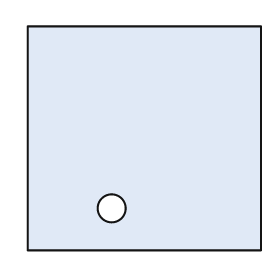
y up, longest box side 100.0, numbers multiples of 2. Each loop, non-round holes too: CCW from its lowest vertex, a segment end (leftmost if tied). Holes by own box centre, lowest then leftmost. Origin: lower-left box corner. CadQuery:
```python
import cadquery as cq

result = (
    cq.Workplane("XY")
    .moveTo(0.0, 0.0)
    .lineTo(100.0, 0.0)
    .lineTo(100.0, 96.0)
    .lineTo(0.0, 96.0)
    .close()
    .moveTo(36.0, 18.0)
    .circle(6.0)
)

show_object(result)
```